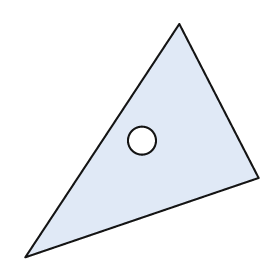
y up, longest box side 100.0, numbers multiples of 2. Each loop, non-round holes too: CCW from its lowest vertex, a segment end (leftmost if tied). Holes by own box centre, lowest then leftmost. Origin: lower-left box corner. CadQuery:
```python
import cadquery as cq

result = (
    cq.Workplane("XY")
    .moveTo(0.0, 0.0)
    .lineTo(100.0, 34.0)
    .lineTo(66.0, 100.0)
    .close()
    .moveTo(50.0, 50.0)
    .circle(6.0)
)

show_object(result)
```